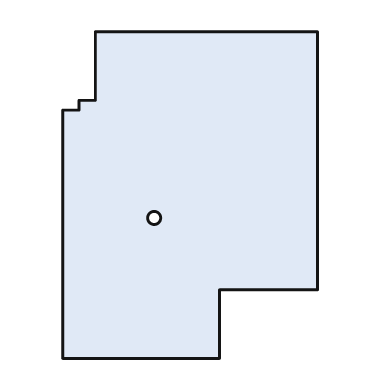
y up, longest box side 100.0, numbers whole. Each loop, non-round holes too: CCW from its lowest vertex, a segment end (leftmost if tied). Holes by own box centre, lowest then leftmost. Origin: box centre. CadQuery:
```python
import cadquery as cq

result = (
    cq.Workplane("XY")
    .moveTo(-39.0, -50.0)
    .lineTo(9.0, -50.0)
    .lineTo(9.0, -29.0)
    .lineTo(39.0, -29.0)
    .lineTo(39.0, 50.0)
    .lineTo(-29.0, 50.0)
    .lineTo(-29.0, 29.0)
    .lineTo(-34.0, 29.0)
    .lineTo(-34.0, 26.0)
    .lineTo(-39.0, 26.0)
    .close()
    .moveTo(-11.0, -7.0)
    .circle(2.0)
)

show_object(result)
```